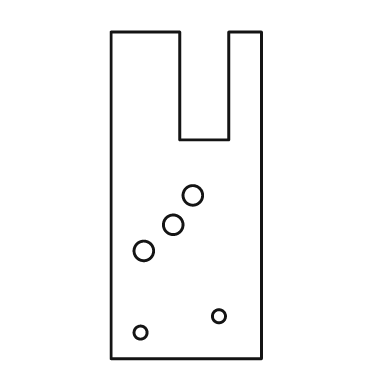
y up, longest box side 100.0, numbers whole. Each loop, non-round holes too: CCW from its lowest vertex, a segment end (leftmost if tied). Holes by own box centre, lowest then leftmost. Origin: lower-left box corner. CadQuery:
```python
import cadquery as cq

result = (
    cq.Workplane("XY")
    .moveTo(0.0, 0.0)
    .lineTo(46.0, 0.0)
    .lineTo(46.0, 100.0)
    .lineTo(36.0, 100.0)
    .lineTo(36.0, 67.0)
    .lineTo(21.0, 67.0)
    .lineTo(21.0, 100.0)
    .lineTo(0.0, 100.0)
    .close()
    .moveTo(9.0, 8.0)
    .circle(2.0)
    .moveTo(33.0, 13.0)
    .circle(2.0)
    .moveTo(10.0, 33.0)
    .circle(3.0)
    .moveTo(19.0, 41.0)
    .circle(3.0)
    .moveTo(25.0, 50.0)
    .circle(3.0)
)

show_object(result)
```